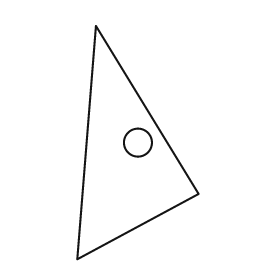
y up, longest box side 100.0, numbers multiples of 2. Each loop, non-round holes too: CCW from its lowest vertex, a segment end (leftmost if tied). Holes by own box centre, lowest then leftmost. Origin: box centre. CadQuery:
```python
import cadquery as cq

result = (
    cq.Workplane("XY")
    .moveTo(-26.0, -50.0)
    .lineTo(26.0, -22.0)
    .lineTo(-18.0, 50.0)
    .close()
    .moveTo(0.0, 0.0)
    .circle(6.0)
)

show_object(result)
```